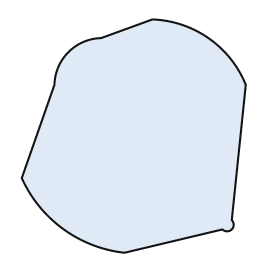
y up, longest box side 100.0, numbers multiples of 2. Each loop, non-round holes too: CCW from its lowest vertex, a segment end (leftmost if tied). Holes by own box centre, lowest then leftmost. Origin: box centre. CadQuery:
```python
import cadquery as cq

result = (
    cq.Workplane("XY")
    .moveTo(-4.0, -50.0)
    .lineTo(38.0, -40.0)
    .threePointArc((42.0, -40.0), (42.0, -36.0))
    .lineTo(48.0, 22.0)
    .threePointArc((32.0, 42.0), (8.0, 50.0))
    .lineTo(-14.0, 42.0)
    .threePointArc((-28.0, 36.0), (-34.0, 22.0))
    .lineTo(-48.0, -18.0)
    .threePointArc((-30.0, -40.0), (-4.0, -50.0))
    .close()
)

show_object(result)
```